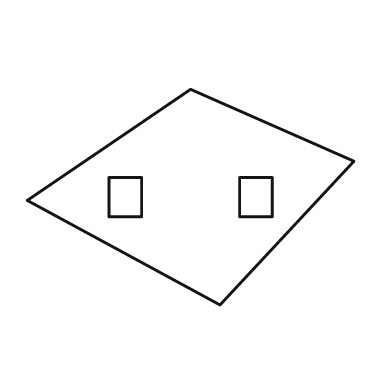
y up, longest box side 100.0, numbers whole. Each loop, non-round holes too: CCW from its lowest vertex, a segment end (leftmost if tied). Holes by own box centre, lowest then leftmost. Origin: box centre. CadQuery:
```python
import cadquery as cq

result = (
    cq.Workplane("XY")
    .moveTo(9.0, -33.0)
    .lineTo(50.0, 11.0)
    .lineTo(0.0, 33.0)
    .lineTo(-50.0, -1.0)
    .close()
    .moveTo(-25.0, -6.0)
    .lineTo(-15.0, -6.0)
    .lineTo(-15.0, 6.0)
    .lineTo(-25.0, 6.0)
    .close()
    .moveTo(15.0, -6.0)
    .lineTo(25.0, -6.0)
    .lineTo(25.0, 6.0)
    .lineTo(15.0, 6.0)
    .close()
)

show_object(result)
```